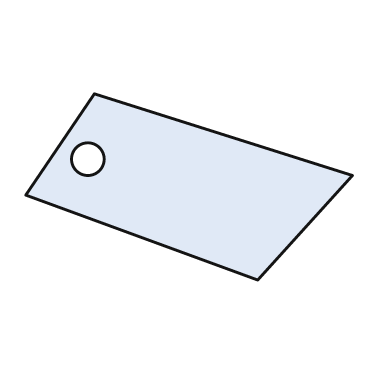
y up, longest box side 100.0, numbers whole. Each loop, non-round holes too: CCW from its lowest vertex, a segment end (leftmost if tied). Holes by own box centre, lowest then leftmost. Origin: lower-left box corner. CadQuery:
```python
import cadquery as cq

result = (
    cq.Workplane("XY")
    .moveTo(71.0, 0.0)
    .lineTo(100.0, 32.0)
    .lineTo(21.0, 57.0)
    .lineTo(0.0, 26.0)
    .close()
    .moveTo(19.0, 37.0)
    .circle(5.0)
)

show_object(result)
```